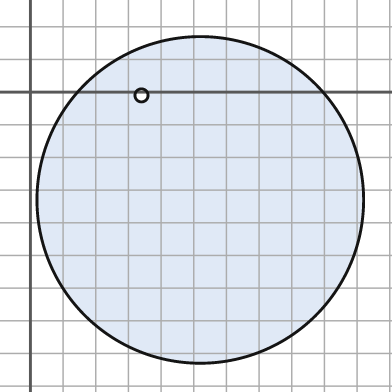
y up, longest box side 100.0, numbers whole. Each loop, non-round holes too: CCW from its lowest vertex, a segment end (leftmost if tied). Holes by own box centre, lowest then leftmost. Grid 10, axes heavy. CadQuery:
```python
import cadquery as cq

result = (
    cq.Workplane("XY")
    .moveTo(52.0, -33.0)
    .circle(50.0)
    .moveTo(34.0, -1.0)
    .circle(2.0)
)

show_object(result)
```